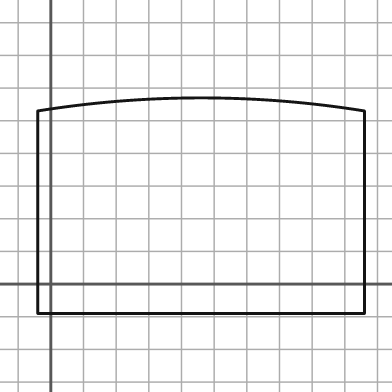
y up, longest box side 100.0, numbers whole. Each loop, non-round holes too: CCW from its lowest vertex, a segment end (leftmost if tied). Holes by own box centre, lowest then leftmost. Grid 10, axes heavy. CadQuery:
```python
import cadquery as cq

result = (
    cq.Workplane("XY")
    .moveTo(-4.0, -9.0)
    .lineTo(96.0, -9.0)
    .lineTo(96.0, 53.0)
    .threePointArc((46.0, 57.0), (-4.0, 53.0))
    .close()
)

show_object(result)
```